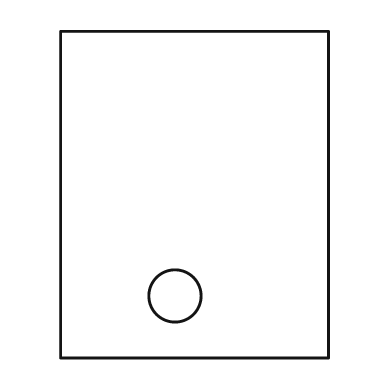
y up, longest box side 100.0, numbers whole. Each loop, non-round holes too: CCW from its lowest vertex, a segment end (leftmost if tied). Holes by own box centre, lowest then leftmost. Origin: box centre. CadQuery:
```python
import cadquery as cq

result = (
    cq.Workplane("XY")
    .moveTo(-41.0, -50.0)
    .lineTo(41.0, -50.0)
    .lineTo(41.0, 50.0)
    .lineTo(-41.0, 50.0)
    .close()
    .moveTo(-6.0, -31.0)
    .circle(8.0)
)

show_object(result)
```